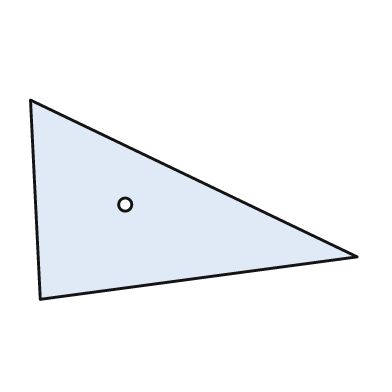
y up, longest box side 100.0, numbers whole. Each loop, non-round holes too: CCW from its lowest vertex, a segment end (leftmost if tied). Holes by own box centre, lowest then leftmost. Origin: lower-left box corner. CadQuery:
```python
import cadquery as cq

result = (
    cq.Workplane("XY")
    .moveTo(3.0, 0.0)
    .lineTo(100.0, 13.0)
    .lineTo(0.0, 61.0)
    .close()
    .moveTo(29.0, 29.0)
    .circle(2.0)
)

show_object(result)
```